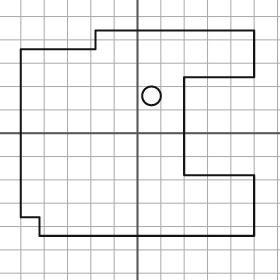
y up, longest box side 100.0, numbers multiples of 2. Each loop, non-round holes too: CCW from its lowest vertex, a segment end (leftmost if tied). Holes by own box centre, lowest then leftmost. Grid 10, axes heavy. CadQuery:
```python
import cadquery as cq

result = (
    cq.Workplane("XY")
    .moveTo(-42.0, -44.0)
    .lineTo(50.0, -44.0)
    .lineTo(50.0, -18.0)
    .lineTo(20.0, -18.0)
    .lineTo(20.0, 24.0)
    .lineTo(50.0, 24.0)
    .lineTo(50.0, 44.0)
    .lineTo(-18.0, 44.0)
    .lineTo(-18.0, 36.0)
    .lineTo(-50.0, 36.0)
    .lineTo(-50.0, -36.0)
    .lineTo(-42.0, -36.0)
    .close()
    .moveTo(6.0, 16.0)
    .circle(4.0)
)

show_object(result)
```